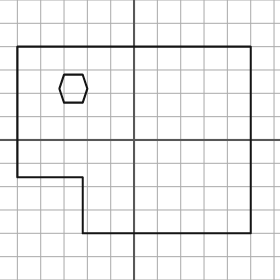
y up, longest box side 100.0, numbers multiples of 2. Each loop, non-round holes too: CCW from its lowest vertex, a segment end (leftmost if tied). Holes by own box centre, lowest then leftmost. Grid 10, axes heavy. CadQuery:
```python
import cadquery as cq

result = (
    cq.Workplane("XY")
    .moveTo(-22.0, -40.0)
    .lineTo(50.0, -40.0)
    .lineTo(50.0, 40.0)
    .lineTo(-50.0, 40.0)
    .lineTo(-50.0, -16.0)
    .lineTo(-22.0, -16.0)
    .close()
    .moveTo(-30.0, 16.0)
    .lineTo(-22.0, 16.0)
    .lineTo(-20.0, 22.0)
    .lineTo(-22.0, 28.0)
    .lineTo(-30.0, 28.0)
    .lineTo(-32.0, 22.0)
    .close()
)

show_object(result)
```